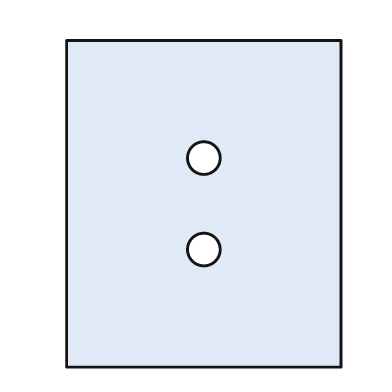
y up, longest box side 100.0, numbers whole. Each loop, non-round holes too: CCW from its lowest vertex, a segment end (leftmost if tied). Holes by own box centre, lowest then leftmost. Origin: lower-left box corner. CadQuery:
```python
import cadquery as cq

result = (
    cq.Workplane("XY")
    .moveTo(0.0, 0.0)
    .lineTo(84.0, 0.0)
    .lineTo(84.0, 100.0)
    .lineTo(0.0, 100.0)
    .close()
    .moveTo(42.0, 36.0)
    .circle(5.0)
    .moveTo(42.0, 64.0)
    .circle(5.0)
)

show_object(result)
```